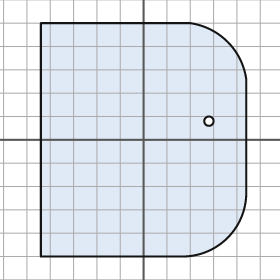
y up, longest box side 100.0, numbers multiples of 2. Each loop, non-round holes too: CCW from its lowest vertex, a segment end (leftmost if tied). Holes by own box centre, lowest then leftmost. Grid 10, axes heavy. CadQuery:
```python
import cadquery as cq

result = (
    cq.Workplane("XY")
    .moveTo(-44.0, -50.0)
    .lineTo(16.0, -50.0)
    .threePointArc((36.0, -42.0), (44.0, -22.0))
    .lineTo(44.0, 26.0)
    .threePointArc((36.0, 42.0), (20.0, 50.0))
    .lineTo(-44.0, 50.0)
    .close()
    .moveTo(28.0, 8.0)
    .circle(2.0)
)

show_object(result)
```